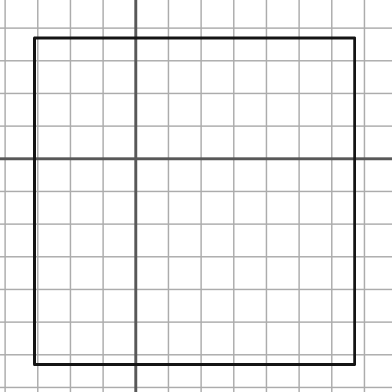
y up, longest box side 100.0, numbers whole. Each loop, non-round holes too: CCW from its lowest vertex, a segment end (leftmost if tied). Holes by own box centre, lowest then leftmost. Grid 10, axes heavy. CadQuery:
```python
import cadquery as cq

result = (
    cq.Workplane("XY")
    .moveTo(-31.0, -63.0)
    .lineTo(67.0, -63.0)
    .lineTo(67.0, 37.0)
    .lineTo(-31.0, 37.0)
    .close()
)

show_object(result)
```